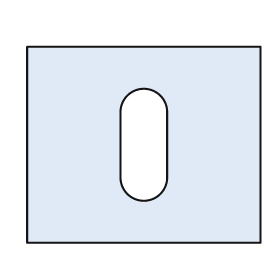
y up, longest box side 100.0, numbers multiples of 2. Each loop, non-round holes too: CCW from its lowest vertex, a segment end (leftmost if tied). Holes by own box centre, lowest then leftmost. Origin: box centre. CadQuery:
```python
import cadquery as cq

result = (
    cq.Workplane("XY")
    .moveTo(-50.0, -42.0)
    .lineTo(50.0, -42.0)
    .lineTo(50.0, 42.0)
    .lineTo(-50.0, 42.0)
    .close()
    .moveTo(-10.0, -14.0)
    .threePointArc((0.0, -24.0), (10.0, -14.0))
    .lineTo(10.0, 14.0)
    .threePointArc((0.0, 24.0), (-10.0, 14.0))
    .close()
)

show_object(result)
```